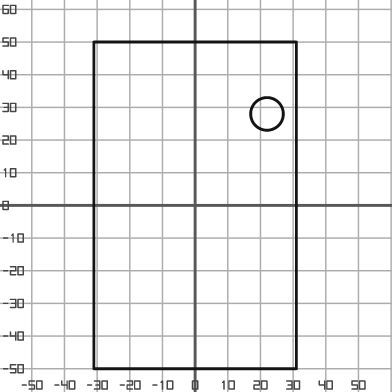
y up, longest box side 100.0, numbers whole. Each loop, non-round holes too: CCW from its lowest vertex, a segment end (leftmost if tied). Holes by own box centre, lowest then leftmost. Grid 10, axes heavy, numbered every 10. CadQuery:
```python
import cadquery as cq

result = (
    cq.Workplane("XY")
    .moveTo(-31.0, -50.0)
    .lineTo(31.0, -50.0)
    .lineTo(31.0, 50.0)
    .lineTo(-31.0, 50.0)
    .close()
    .moveTo(22.0, 28.0)
    .circle(5.0)
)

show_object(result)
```